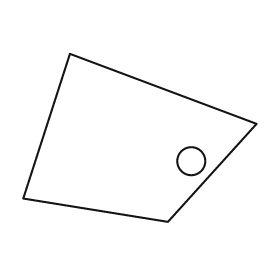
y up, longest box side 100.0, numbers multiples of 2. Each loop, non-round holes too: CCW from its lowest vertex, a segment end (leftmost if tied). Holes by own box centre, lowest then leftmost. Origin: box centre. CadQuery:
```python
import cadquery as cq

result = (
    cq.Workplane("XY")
    .moveTo(12.0, -36.0)
    .lineTo(50.0, 6.0)
    .lineTo(-30.0, 36.0)
    .lineTo(-50.0, -26.0)
    .close()
    .moveTo(22.0, -10.0)
    .circle(6.0)
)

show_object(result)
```